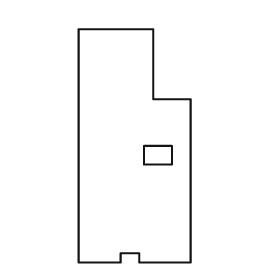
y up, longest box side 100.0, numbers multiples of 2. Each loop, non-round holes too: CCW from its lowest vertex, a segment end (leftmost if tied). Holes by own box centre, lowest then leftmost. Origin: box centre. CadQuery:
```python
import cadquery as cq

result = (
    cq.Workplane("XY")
    .moveTo(-24.0, -50.0)
    .lineTo(-6.0, -50.0)
    .lineTo(-6.0, -46.0)
    .lineTo(2.0, -46.0)
    .lineTo(2.0, -50.0)
    .lineTo(24.0, -50.0)
    .lineTo(24.0, 20.0)
    .lineTo(8.0, 20.0)
    .lineTo(8.0, 50.0)
    .lineTo(-24.0, 50.0)
    .close()
    .moveTo(4.0, -8.0)
    .lineTo(16.0, -8.0)
    .lineTo(16.0, 0.0)
    .lineTo(4.0, 0.0)
    .close()
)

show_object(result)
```